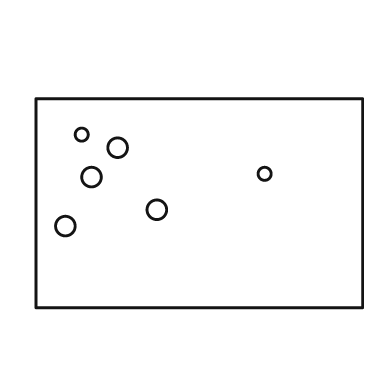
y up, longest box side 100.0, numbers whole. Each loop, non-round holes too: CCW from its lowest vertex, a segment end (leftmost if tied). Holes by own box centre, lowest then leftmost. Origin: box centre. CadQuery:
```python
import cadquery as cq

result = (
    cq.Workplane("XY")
    .moveTo(-50.0, -32.0)
    .lineTo(50.0, -32.0)
    .lineTo(50.0, 32.0)
    .lineTo(-50.0, 32.0)
    .close()
    .moveTo(-41.0, -7.0)
    .circle(3.0)
    .moveTo(-13.0, -2.0)
    .circle(3.0)
    .moveTo(-33.0, 8.0)
    .circle(3.0)
    .moveTo(20.0, 9.0)
    .circle(2.0)
    .moveTo(-25.0, 17.0)
    .circle(3.0)
    .moveTo(-36.0, 21.0)
    .circle(2.0)
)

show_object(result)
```